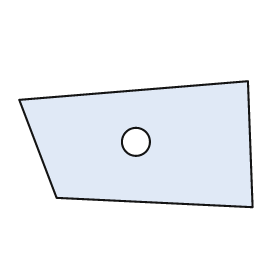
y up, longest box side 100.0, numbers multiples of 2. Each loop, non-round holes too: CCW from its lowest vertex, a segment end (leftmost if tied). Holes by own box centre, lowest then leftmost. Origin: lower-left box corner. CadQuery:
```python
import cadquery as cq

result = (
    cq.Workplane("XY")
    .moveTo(100.0, 0.0)
    .lineTo(98.0, 54.0)
    .lineTo(0.0, 46.0)
    .lineTo(16.0, 4.0)
    .close()
    .moveTo(50.0, 28.0)
    .circle(6.0)
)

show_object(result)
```